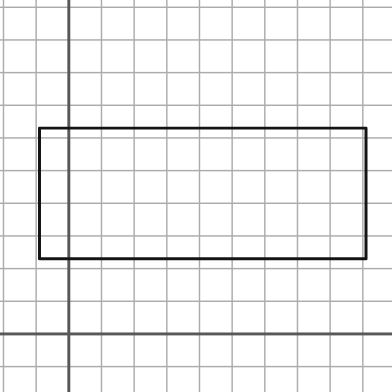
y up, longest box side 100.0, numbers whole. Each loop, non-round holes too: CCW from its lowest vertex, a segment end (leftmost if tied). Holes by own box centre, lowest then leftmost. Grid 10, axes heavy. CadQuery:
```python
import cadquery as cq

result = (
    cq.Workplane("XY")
    .moveTo(-9.0, 23.0)
    .lineTo(91.0, 23.0)
    .lineTo(91.0, 63.0)
    .lineTo(-9.0, 63.0)
    .close()
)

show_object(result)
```